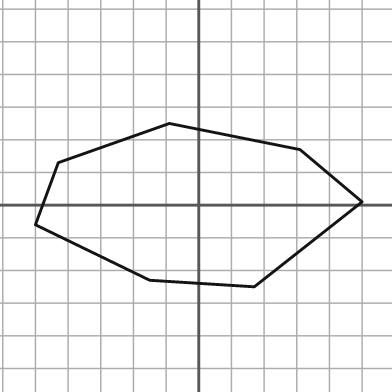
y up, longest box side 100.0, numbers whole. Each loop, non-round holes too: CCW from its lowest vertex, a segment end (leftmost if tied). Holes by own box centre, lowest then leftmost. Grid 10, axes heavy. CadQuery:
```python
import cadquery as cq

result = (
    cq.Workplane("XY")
    .moveTo(17.0, -25.0)
    .lineTo(50.0, 1.0)
    .lineTo(31.0, 17.0)
    .lineTo(-9.0, 25.0)
    .lineTo(-43.0, 13.0)
    .lineTo(-50.0, -6.0)
    .lineTo(-15.0, -23.0)
    .close()
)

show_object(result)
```